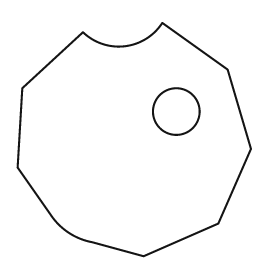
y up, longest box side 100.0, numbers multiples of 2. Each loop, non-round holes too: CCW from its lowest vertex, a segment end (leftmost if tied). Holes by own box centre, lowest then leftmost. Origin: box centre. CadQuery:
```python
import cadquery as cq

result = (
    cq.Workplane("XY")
    .moveTo(4.0, -50.0)
    .lineTo(36.0, -36.0)
    .lineTo(50.0, -4.0)
    .lineTo(40.0, 30.0)
    .lineTo(12.0, 50.0)
    .threePointArc((-4.0, 40.0), (-22.0, 46.0))
    .lineTo(-48.0, 22.0)
    .lineTo(-50.0, -12.0)
    .lineTo(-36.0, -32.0)
    .threePointArc((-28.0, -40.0), (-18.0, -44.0))
    .close()
    .moveTo(18.0, 12.0)
    .circle(10.0)
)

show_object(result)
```